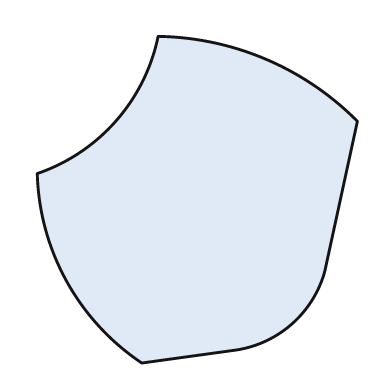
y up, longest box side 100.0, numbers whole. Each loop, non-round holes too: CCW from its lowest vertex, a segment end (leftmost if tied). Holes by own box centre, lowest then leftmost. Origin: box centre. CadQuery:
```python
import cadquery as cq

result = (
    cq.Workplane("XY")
    .moveTo(-17.0, -50.0)
    .lineTo(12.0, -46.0)
    .threePointArc((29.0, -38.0), (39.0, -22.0))
    .lineTo(49.0, 24.0)
    .threePointArc((21.0, 43.0), (-12.0, 50.0))
    .threePointArc((-25.0, 24.0), (-49.0, 8.0))
    .threePointArc((-40.0, -25.0), (-17.0, -50.0))
    .close()
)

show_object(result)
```